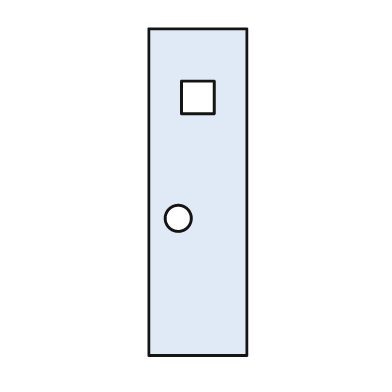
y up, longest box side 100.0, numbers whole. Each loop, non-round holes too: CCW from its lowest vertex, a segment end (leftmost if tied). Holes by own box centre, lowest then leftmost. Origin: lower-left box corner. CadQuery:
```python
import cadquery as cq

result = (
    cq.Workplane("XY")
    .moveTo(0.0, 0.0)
    .lineTo(30.0, 0.0)
    .lineTo(30.0, 100.0)
    .lineTo(0.0, 100.0)
    .close()
    .moveTo(9.0, 42.0)
    .circle(4.0)
    .moveTo(10.0, 74.0)
    .lineTo(20.0, 74.0)
    .lineTo(20.0, 84.0)
    .lineTo(10.0, 84.0)
    .close()
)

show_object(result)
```